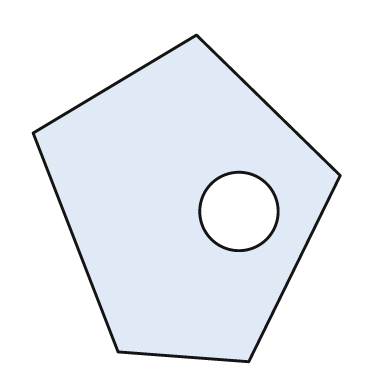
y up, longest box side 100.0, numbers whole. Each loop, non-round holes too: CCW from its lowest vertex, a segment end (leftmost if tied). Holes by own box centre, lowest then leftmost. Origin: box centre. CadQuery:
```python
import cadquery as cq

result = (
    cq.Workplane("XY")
    .moveTo(19.0, -50.0)
    .lineTo(47.0, 7.0)
    .lineTo(3.0, 50.0)
    .lineTo(-47.0, 20.0)
    .lineTo(-21.0, -47.0)
    .close()
    .moveTo(16.0, -4.0)
    .circle(12.0)
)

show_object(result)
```